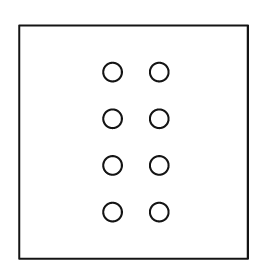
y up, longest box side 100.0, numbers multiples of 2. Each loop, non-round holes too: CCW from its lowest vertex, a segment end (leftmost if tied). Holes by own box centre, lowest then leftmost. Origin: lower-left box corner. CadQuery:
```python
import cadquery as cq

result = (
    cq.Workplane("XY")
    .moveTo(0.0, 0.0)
    .lineTo(98.0, 0.0)
    .lineTo(98.0, 100.0)
    .lineTo(0.0, 100.0)
    .close()
    .moveTo(40.0, 20.0)
    .circle(4.0)
    .moveTo(60.0, 20.0)
    .circle(4.0)
    .moveTo(40.0, 40.0)
    .circle(4.0)
    .moveTo(60.0, 40.0)
    .circle(4.0)
    .moveTo(40.0, 60.0)
    .circle(4.0)
    .moveTo(60.0, 60.0)
    .circle(4.0)
    .moveTo(40.0, 80.0)
    .circle(4.0)
    .moveTo(60.0, 80.0)
    .circle(4.0)
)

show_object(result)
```